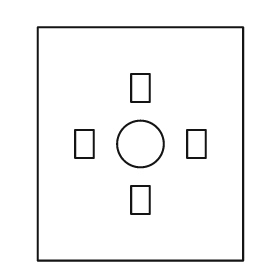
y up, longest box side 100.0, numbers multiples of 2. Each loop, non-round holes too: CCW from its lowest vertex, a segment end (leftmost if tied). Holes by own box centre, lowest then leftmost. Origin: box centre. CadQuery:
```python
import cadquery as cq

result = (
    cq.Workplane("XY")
    .moveTo(-44.0, -50.0)
    .lineTo(44.0, -50.0)
    .lineTo(44.0, 50.0)
    .lineTo(-44.0, 50.0)
    .close()
    .moveTo(-4.0, -30.0)
    .lineTo(4.0, -30.0)
    .lineTo(4.0, -18.0)
    .lineTo(-4.0, -18.0)
    .close()
    .moveTo(-28.0, -6.0)
    .lineTo(-20.0, -6.0)
    .lineTo(-20.0, 6.0)
    .lineTo(-28.0, 6.0)
    .close()
    .moveTo(0.0, 0.0)
    .circle(10.0)
    .moveTo(20.0, -6.0)
    .lineTo(28.0, -6.0)
    .lineTo(28.0, 6.0)
    .lineTo(20.0, 6.0)
    .close()
    .moveTo(-4.0, 18.0)
    .lineTo(4.0, 18.0)
    .lineTo(4.0, 30.0)
    .lineTo(-4.0, 30.0)
    .close()
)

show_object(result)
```